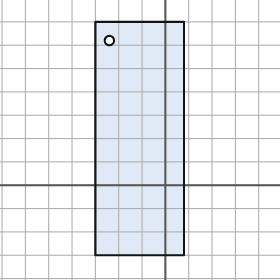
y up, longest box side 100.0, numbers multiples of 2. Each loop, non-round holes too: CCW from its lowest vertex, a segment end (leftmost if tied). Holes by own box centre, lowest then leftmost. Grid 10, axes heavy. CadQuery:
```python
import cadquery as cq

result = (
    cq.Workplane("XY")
    .moveTo(-30.0, -30.0)
    .lineTo(8.0, -30.0)
    .lineTo(8.0, 70.0)
    .lineTo(-30.0, 70.0)
    .close()
    .moveTo(-24.0, 62.0)
    .circle(2.0)
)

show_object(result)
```